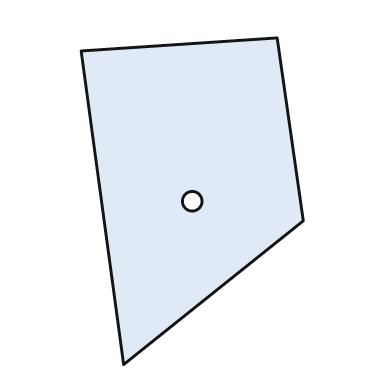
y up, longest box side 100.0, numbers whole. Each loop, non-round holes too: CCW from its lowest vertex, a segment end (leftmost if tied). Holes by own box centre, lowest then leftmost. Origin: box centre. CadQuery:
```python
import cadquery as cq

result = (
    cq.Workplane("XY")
    .moveTo(-21.0, -50.0)
    .lineTo(34.0, -6.0)
    .lineTo(26.0, 50.0)
    .lineTo(-34.0, 46.0)
    .close()
    .moveTo(0.0, 0.0)
    .circle(3.0)
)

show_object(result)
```